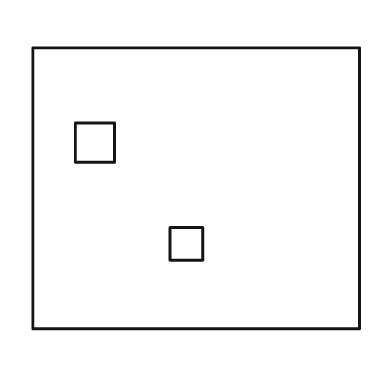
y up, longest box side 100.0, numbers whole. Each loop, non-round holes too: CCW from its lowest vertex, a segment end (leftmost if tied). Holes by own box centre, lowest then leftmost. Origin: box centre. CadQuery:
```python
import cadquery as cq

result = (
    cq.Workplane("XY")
    .moveTo(-50.0, -43.0)
    .lineTo(50.0, -43.0)
    .lineTo(50.0, 43.0)
    .lineTo(-50.0, 43.0)
    .close()
    .moveTo(-8.0, -22.0)
    .lineTo(2.0, -22.0)
    .lineTo(2.0, -12.0)
    .lineTo(-8.0, -12.0)
    .close()
    .moveTo(-37.0, 8.0)
    .lineTo(-25.0, 8.0)
    .lineTo(-25.0, 20.0)
    .lineTo(-37.0, 20.0)
    .close()
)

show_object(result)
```